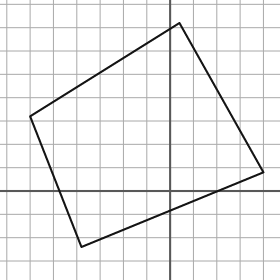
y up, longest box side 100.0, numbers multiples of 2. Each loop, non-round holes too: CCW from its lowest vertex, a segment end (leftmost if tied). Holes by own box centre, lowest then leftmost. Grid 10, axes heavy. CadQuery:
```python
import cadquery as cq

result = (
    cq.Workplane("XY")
    .moveTo(-38.0, -24.0)
    .lineTo(40.0, 8.0)
    .lineTo(4.0, 72.0)
    .lineTo(-60.0, 32.0)
    .close()
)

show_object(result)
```